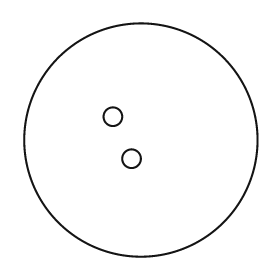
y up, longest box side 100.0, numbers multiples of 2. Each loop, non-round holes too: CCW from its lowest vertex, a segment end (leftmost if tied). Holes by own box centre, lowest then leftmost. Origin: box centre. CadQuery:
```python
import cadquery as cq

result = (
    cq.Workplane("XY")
    .moveTo(0.0, 0.0)
    .circle(50.0)
    .moveTo(-4.0, -8.0)
    .circle(4.0)
    .moveTo(-12.0, 10.0)
    .circle(4.0)
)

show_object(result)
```